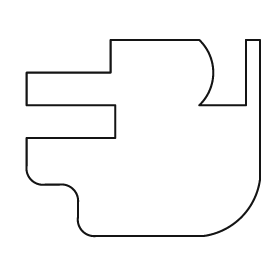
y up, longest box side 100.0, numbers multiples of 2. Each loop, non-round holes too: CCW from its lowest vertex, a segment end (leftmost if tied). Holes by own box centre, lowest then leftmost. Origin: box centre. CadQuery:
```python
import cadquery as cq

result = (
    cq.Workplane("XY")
    .moveTo(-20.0, -42.0)
    .lineTo(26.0, -42.0)
    .threePointArc((42.0, -34.0), (50.0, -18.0))
    .lineTo(50.0, 42.0)
    .lineTo(44.0, 42.0)
    .lineTo(44.0, 14.0)
    .lineTo(24.0, 14.0)
    .threePointArc((30.0, 28.0), (24.0, 42.0))
    .lineTo(-14.0, 42.0)
    .lineTo(-14.0, 28.0)
    .lineTo(-50.0, 28.0)
    .lineTo(-50.0, 14.0)
    .lineTo(-12.0, 14.0)
    .lineTo(-12.0, 0.0)
    .lineTo(-50.0, 0.0)
    .lineTo(-50.0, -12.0)
    .threePointArc((-48.0, -18.0), (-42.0, -20.0))
    .lineTo(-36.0, -20.0)
    .threePointArc((-30.0, -22.0), (-28.0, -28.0))
    .lineTo(-28.0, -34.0)
    .threePointArc((-26.0, -40.0), (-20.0, -42.0))
    .close()
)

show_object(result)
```